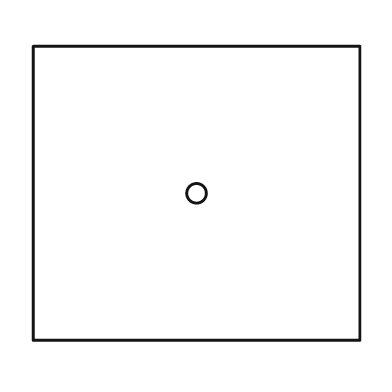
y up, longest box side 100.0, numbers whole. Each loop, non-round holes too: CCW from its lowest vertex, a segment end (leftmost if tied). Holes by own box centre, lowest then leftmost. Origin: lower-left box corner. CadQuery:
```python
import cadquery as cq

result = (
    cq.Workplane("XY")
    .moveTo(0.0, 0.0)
    .lineTo(100.0, 0.0)
    .lineTo(100.0, 90.0)
    .lineTo(0.0, 90.0)
    .close()
    .moveTo(50.0, 45.0)
    .circle(3.0)
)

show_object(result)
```